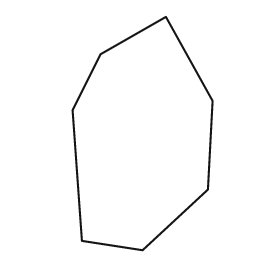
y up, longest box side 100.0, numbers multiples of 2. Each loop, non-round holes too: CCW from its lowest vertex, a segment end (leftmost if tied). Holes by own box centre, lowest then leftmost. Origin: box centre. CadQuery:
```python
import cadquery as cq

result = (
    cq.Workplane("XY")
    .moveTo(0.0, -50.0)
    .lineTo(28.0, -24.0)
    .lineTo(30.0, 14.0)
    .lineTo(10.0, 50.0)
    .lineTo(-18.0, 34.0)
    .lineTo(-30.0, 10.0)
    .lineTo(-26.0, -46.0)
    .close()
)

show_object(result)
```